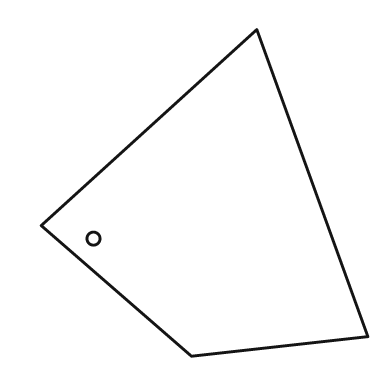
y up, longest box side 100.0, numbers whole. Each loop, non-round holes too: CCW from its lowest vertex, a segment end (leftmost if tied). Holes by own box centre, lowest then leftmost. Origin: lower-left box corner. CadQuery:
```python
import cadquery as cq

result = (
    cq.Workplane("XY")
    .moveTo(46.0, 0.0)
    .lineTo(100.0, 6.0)
    .lineTo(66.0, 100.0)
    .lineTo(0.0, 40.0)
    .close()
    .moveTo(16.0, 36.0)
    .circle(2.0)
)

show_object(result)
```